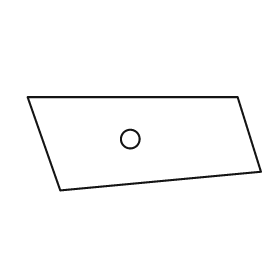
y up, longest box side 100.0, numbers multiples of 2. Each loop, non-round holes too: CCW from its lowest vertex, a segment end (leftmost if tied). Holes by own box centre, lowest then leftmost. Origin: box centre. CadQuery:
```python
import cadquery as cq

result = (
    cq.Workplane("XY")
    .moveTo(-36.0, -20.0)
    .lineTo(50.0, -12.0)
    .lineTo(40.0, 20.0)
    .lineTo(-50.0, 20.0)
    .close()
    .moveTo(-6.0, 2.0)
    .circle(4.0)
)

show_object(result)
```